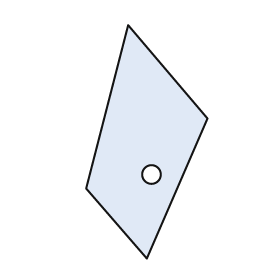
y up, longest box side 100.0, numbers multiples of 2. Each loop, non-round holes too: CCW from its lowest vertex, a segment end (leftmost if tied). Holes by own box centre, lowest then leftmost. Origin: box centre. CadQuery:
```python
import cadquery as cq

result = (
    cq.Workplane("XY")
    .moveTo(0.0, -50.0)
    .lineTo(26.0, 10.0)
    .lineTo(-8.0, 50.0)
    .lineTo(-26.0, -20.0)
    .close()
    .moveTo(2.0, -14.0)
    .circle(4.0)
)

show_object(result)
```